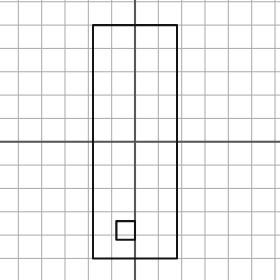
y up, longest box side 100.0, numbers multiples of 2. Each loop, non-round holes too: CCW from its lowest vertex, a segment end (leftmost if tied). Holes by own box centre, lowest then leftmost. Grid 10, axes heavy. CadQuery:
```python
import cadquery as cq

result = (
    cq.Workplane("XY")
    .moveTo(-18.0, -50.0)
    .lineTo(18.0, -50.0)
    .lineTo(18.0, 50.0)
    .lineTo(-18.0, 50.0)
    .close()
    .moveTo(-8.0, -42.0)
    .lineTo(0.0, -42.0)
    .lineTo(0.0, -34.0)
    .lineTo(-8.0, -34.0)
    .close()
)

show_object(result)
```